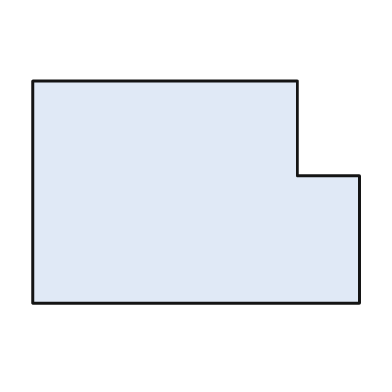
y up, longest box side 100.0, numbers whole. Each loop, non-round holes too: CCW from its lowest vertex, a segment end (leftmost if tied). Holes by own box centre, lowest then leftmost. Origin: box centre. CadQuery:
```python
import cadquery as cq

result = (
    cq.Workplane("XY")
    .moveTo(-50.0, -34.0)
    .lineTo(50.0, -34.0)
    .lineTo(50.0, 5.0)
    .lineTo(31.0, 5.0)
    .lineTo(31.0, 34.0)
    .lineTo(-50.0, 34.0)
    .close()
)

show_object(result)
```